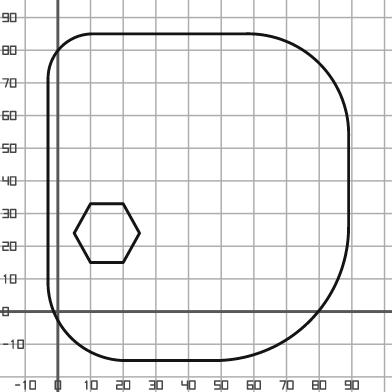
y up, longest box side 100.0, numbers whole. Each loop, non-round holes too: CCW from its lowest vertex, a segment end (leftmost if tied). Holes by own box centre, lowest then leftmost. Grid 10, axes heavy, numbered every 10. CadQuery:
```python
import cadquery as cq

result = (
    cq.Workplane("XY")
    .moveTo(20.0, -15.0)
    .lineTo(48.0, -15.0)
    .threePointArc((77.0, -3.0), (89.0, 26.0))
    .lineTo(89.0, 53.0)
    .threePointArc((80.0, 76.0), (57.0, 85.0))
    .lineTo(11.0, 85.0)
    .threePointArc((1.0, 81.0), (-3.0, 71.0))
    .lineTo(-3.0, 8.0)
    .threePointArc((4.0, -8.0), (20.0, -15.0))
    .close()
    .moveTo(10.0, 15.0)
    .lineTo(20.0, 15.0)
    .lineTo(25.0, 24.0)
    .lineTo(20.0, 33.0)
    .lineTo(10.0, 33.0)
    .lineTo(5.0, 24.0)
    .close()
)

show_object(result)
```